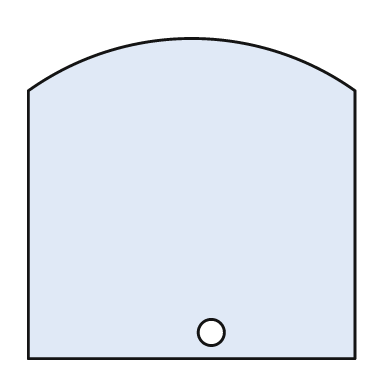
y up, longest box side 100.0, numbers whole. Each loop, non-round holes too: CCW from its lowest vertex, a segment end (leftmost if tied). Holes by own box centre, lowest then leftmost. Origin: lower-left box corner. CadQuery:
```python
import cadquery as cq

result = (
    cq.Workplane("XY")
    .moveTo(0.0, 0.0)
    .lineTo(100.0, 0.0)
    .lineTo(100.0, 82.0)
    .threePointArc((50.0, 98.0), (0.0, 82.0))
    .close()
    .moveTo(56.0, 8.0)
    .circle(4.0)
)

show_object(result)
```